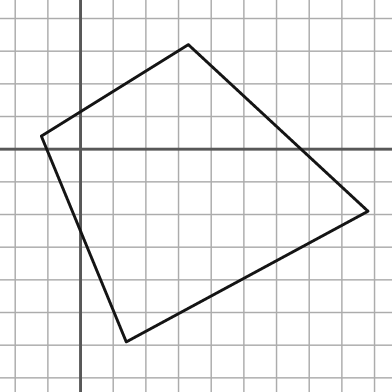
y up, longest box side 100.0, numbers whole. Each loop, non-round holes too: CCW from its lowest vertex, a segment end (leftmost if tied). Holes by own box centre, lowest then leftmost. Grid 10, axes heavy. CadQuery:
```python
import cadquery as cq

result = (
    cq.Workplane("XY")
    .moveTo(14.0, -59.0)
    .lineTo(88.0, -19.0)
    .lineTo(33.0, 32.0)
    .lineTo(-12.0, 4.0)
    .close()
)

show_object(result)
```